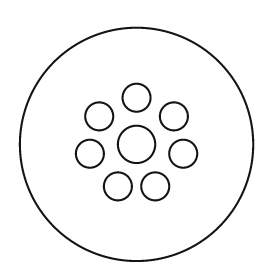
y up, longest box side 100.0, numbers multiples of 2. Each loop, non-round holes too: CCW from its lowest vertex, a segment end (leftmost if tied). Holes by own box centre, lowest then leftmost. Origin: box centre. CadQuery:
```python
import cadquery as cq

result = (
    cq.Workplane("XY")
    .moveTo(0.0, 0.0)
    .circle(50.0)
    .moveTo(-8.0, -18.0)
    .circle(6.0)
    .moveTo(8.0, -18.0)
    .circle(6.0)
    .moveTo(-20.0, -4.0)
    .circle(6.0)
    .moveTo(20.0, -4.0)
    .circle(6.0)
    .moveTo(0.0, 0.0)
    .circle(8.0)
    .moveTo(-16.0, 12.0)
    .circle(6.0)
    .moveTo(16.0, 12.0)
    .circle(6.0)
    .moveTo(0.0, 20.0)
    .circle(6.0)
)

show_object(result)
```